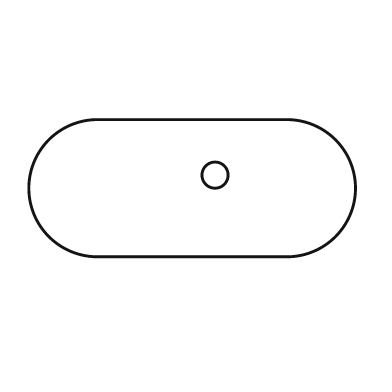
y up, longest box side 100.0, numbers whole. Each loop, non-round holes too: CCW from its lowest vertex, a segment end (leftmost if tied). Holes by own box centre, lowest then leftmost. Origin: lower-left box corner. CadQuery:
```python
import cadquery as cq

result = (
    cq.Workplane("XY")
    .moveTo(21.0, 0.0)
    .lineTo(79.0, 0.0)
    .threePointArc((100.0, 21.0), (79.0, 42.0))
    .lineTo(21.0, 42.0)
    .threePointArc((0.0, 21.0), (21.0, 0.0))
    .close()
    .moveTo(57.0, 25.0)
    .circle(4.0)
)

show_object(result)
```